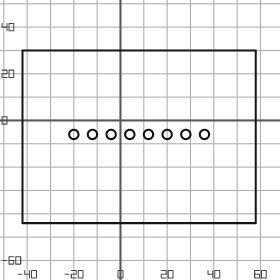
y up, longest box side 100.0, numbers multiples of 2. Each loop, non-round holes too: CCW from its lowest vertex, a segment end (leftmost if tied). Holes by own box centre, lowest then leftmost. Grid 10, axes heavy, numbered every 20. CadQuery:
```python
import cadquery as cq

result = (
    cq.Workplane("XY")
    .moveTo(-42.0, -44.0)
    .lineTo(58.0, -44.0)
    .lineTo(58.0, 30.0)
    .lineTo(-42.0, 30.0)
    .close()
    .moveTo(-20.0, -6.0)
    .circle(2.0)
    .moveTo(-12.0, -6.0)
    .circle(2.0)
    .moveTo(-4.0, -6.0)
    .circle(2.0)
    .moveTo(4.0, -6.0)
    .circle(2.0)
    .moveTo(12.0, -6.0)
    .circle(2.0)
    .moveTo(20.0, -6.0)
    .circle(2.0)
    .moveTo(28.0, -6.0)
    .circle(2.0)
    .moveTo(36.0, -6.0)
    .circle(2.0)
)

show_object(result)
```